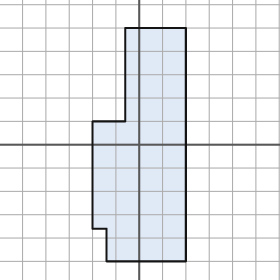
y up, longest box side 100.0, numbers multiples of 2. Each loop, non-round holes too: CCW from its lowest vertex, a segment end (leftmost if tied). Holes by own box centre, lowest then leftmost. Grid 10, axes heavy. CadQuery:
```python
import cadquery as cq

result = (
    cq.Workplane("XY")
    .moveTo(-14.0, -50.0)
    .lineTo(20.0, -50.0)
    .lineTo(20.0, 50.0)
    .lineTo(-6.0, 50.0)
    .lineTo(-6.0, 10.0)
    .lineTo(-20.0, 10.0)
    .lineTo(-20.0, -36.0)
    .lineTo(-14.0, -36.0)
    .close()
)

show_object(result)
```